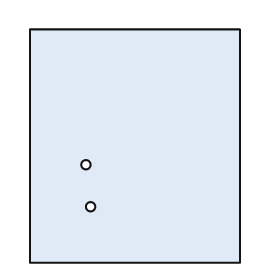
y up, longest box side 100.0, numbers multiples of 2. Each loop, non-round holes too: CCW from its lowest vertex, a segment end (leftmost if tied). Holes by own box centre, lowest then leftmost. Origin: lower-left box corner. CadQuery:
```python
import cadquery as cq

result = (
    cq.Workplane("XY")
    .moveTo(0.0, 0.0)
    .lineTo(90.0, 0.0)
    .lineTo(90.0, 100.0)
    .lineTo(0.0, 100.0)
    .close()
    .moveTo(26.0, 24.0)
    .circle(2.0)
    .moveTo(24.0, 42.0)
    .circle(2.0)
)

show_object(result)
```